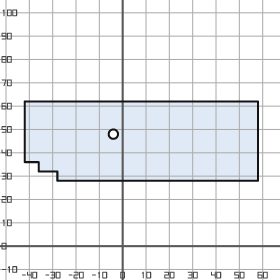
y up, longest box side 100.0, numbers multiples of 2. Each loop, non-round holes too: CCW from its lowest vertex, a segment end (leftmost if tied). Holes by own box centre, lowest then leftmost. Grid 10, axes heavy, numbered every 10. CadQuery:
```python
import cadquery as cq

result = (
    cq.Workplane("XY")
    .moveTo(-28.0, 28.0)
    .lineTo(58.0, 28.0)
    .lineTo(58.0, 62.0)
    .lineTo(-42.0, 62.0)
    .lineTo(-42.0, 36.0)
    .lineTo(-36.0, 36.0)
    .lineTo(-36.0, 32.0)
    .lineTo(-28.0, 32.0)
    .close()
    .moveTo(-4.0, 48.0)
    .circle(2.0)
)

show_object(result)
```